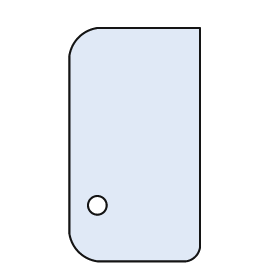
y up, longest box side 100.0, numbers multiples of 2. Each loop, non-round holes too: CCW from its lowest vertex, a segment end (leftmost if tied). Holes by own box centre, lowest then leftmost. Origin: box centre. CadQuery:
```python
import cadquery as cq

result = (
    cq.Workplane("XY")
    .moveTo(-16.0, -50.0)
    .lineTo(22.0, -50.0)
    .threePointArc((26.0, -48.0), (28.0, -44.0))
    .lineTo(28.0, 50.0)
    .lineTo(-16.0, 50.0)
    .threePointArc((-24.0, 46.0), (-28.0, 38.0))
    .lineTo(-28.0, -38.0)
    .threePointArc((-24.0, -46.0), (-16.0, -50.0))
    .close()
    .moveTo(-16.0, -26.0)
    .circle(4.0)
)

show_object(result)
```